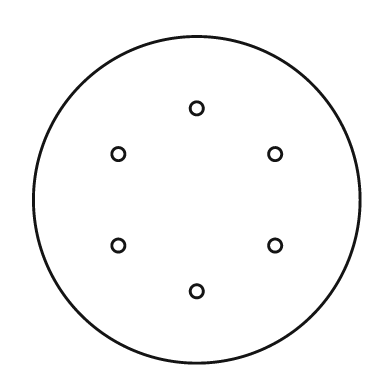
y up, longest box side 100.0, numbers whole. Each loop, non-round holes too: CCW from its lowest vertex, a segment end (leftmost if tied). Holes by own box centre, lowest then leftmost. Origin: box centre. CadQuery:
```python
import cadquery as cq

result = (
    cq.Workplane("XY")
    .moveTo(0.0, 0.0)
    .circle(50.0)
    .moveTo(0.0, -28.0)
    .circle(2.0)
    .moveTo(-24.0, -14.0)
    .circle(2.0)
    .moveTo(24.0, -14.0)
    .circle(2.0)
    .moveTo(-24.0, 14.0)
    .circle(2.0)
    .moveTo(24.0, 14.0)
    .circle(2.0)
    .moveTo(0.0, 28.0)
    .circle(2.0)
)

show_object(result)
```